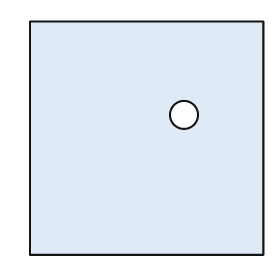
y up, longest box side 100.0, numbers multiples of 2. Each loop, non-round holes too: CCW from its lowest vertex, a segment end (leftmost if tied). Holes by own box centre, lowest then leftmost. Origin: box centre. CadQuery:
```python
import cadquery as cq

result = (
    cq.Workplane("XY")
    .moveTo(-50.0, -50.0)
    .lineTo(50.0, -50.0)
    .lineTo(50.0, 50.0)
    .lineTo(-50.0, 50.0)
    .close()
    .moveTo(16.0, 10.0)
    .circle(6.0)
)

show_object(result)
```